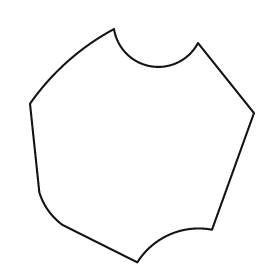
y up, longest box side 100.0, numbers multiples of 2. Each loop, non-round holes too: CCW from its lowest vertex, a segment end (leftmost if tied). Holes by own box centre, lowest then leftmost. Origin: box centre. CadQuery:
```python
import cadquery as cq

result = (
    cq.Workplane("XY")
    .moveTo(-2.0, -50.0)
    .threePointArc((12.0, -38.0), (30.0, -36.0))
    .lineTo(48.0, 14.0)
    .lineTo(24.0, 44.0)
    .threePointArc((4.0, 34.0), (-12.0, 50.0))
    .threePointArc((-32.0, 36.0), (-48.0, 18.0))
    .lineTo(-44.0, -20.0)
    .threePointArc((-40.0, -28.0), (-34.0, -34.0))
    .close()
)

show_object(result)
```